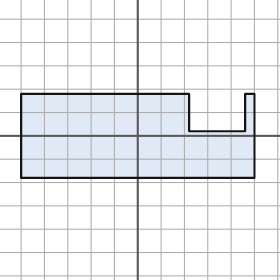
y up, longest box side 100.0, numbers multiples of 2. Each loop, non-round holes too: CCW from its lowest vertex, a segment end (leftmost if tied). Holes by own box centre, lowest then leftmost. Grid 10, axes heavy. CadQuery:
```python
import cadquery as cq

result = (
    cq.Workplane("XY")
    .moveTo(-50.0, -18.0)
    .lineTo(50.0, -18.0)
    .lineTo(50.0, 18.0)
    .lineTo(46.0, 18.0)
    .lineTo(46.0, 2.0)
    .lineTo(22.0, 2.0)
    .lineTo(22.0, 18.0)
    .lineTo(-50.0, 18.0)
    .close()
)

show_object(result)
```